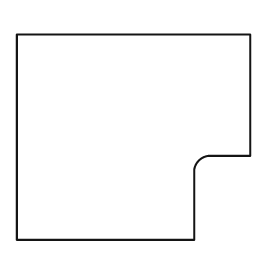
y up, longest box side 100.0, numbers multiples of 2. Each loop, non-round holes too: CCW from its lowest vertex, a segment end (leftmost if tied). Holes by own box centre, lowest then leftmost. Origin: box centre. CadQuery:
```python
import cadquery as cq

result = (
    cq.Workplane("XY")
    .moveTo(-50.0, -44.0)
    .lineTo(26.0, -44.0)
    .lineTo(26.0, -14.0)
    .threePointArc((28.0, -10.0), (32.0, -8.0))
    .lineTo(50.0, -8.0)
    .lineTo(50.0, 44.0)
    .lineTo(-50.0, 44.0)
    .close()
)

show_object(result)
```